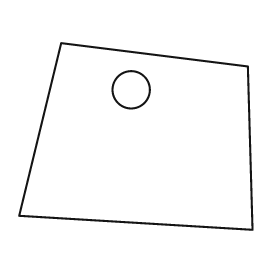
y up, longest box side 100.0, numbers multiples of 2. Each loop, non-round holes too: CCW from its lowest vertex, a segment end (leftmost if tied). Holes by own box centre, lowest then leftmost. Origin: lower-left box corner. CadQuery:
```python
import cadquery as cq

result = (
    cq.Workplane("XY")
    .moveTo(100.0, 0.0)
    .lineTo(98.0, 70.0)
    .lineTo(18.0, 80.0)
    .lineTo(0.0, 6.0)
    .close()
    .moveTo(48.0, 60.0)
    .circle(8.0)
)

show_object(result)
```